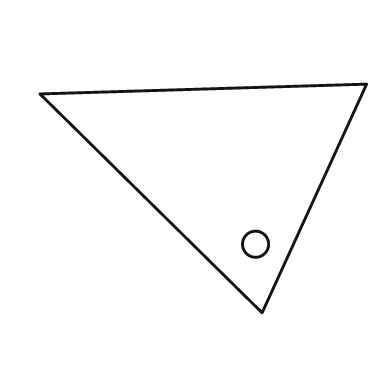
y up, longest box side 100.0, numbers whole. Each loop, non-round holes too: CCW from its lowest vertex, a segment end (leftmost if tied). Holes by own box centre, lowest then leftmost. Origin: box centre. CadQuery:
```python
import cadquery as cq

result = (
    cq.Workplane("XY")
    .moveTo(18.0, -35.0)
    .lineTo(50.0, 35.0)
    .lineTo(-50.0, 32.0)
    .close()
    .moveTo(16.0, -14.0)
    .circle(4.0)
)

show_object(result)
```